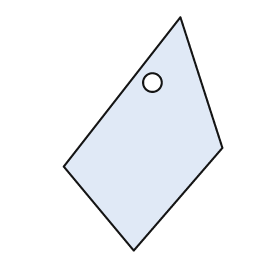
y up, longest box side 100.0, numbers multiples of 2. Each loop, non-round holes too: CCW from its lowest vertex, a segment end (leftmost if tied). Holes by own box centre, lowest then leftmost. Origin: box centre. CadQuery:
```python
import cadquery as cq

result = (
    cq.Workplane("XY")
    .moveTo(-4.0, -50.0)
    .lineTo(34.0, -6.0)
    .lineTo(16.0, 50.0)
    .lineTo(-34.0, -14.0)
    .close()
    .moveTo(4.0, 22.0)
    .circle(4.0)
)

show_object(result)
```